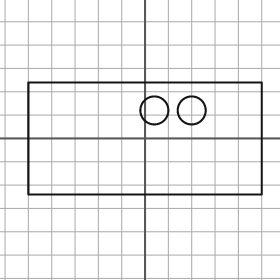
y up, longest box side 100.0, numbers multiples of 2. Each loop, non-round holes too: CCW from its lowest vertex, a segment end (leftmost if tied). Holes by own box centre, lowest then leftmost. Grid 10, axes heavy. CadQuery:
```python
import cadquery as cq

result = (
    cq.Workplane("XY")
    .moveTo(-50.0, -24.0)
    .lineTo(50.0, -24.0)
    .lineTo(50.0, 24.0)
    .lineTo(-50.0, 24.0)
    .close()
    .moveTo(4.0, 12.0)
    .circle(6.0)
    .moveTo(20.0, 12.0)
    .circle(6.0)
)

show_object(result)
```